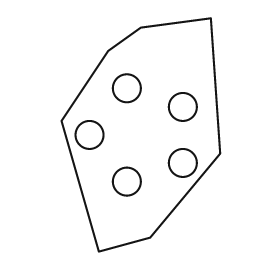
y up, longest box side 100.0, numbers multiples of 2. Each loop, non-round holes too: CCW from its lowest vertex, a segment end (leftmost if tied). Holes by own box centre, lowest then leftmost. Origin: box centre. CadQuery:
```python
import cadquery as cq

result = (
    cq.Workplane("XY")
    .moveTo(-18.0, -50.0)
    .lineTo(4.0, -44.0)
    .lineTo(34.0, -8.0)
    .lineTo(30.0, 50.0)
    .lineTo(0.0, 46.0)
    .lineTo(-14.0, 36.0)
    .lineTo(-34.0, 6.0)
    .close()
    .moveTo(-6.0, -20.0)
    .circle(6.0)
    .moveTo(18.0, -12.0)
    .circle(6.0)
    .moveTo(-22.0, 0.0)
    .circle(6.0)
    .moveTo(18.0, 12.0)
    .circle(6.0)
    .moveTo(-6.0, 20.0)
    .circle(6.0)
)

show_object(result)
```